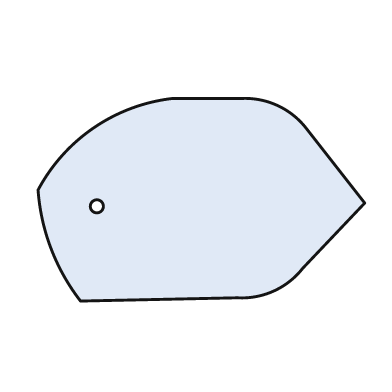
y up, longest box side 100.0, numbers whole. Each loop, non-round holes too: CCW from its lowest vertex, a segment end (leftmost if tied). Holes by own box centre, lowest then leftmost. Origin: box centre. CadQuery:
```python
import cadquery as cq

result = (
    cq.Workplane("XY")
    .moveTo(-37.0, -31.0)
    .lineTo(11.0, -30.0)
    .threePointArc((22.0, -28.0), (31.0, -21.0))
    .lineTo(50.0, -1.0)
    .lineTo(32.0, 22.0)
    .threePointArc((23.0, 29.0), (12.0, 31.0))
    .lineTo(-9.0, 31.0)
    .threePointArc((-33.0, 22.0), (-50.0, 3.0))
    .threePointArc((-46.0, -15.0), (-37.0, -31.0))
    .close()
    .moveTo(-32.0, -2.0)
    .circle(2.0)
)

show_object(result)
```